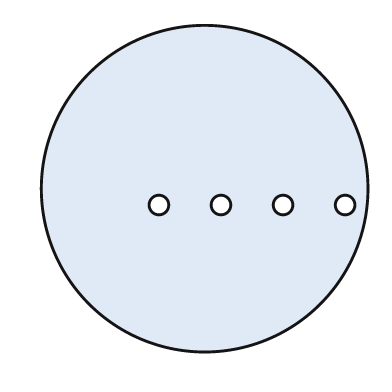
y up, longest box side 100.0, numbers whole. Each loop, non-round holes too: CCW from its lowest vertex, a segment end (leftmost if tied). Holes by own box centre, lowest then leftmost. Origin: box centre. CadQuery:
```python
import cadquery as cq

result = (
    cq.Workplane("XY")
    .moveTo(0.0, 0.0)
    .circle(50.0)
    .moveTo(-14.0, -5.0)
    .circle(3.0)
    .moveTo(5.0, -5.0)
    .circle(3.0)
    .moveTo(24.0, -5.0)
    .circle(3.0)
    .moveTo(43.0, -5.0)
    .circle(3.0)
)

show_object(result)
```